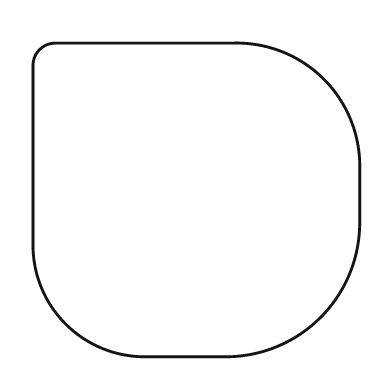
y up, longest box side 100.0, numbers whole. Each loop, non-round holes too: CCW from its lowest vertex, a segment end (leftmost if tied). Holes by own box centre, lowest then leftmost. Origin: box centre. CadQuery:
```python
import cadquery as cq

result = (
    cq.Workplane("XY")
    .moveTo(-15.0, -48.0)
    .lineTo(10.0, -48.0)
    .threePointArc((38.0, -36.0), (50.0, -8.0))
    .lineTo(50.0, 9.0)
    .threePointArc((39.0, 37.0), (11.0, 48.0))
    .lineTo(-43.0, 48.0)
    .threePointArc((-48.0, 46.0), (-50.0, 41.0))
    .lineTo(-50.0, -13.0)
    .threePointArc((-40.0, -38.0), (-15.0, -48.0))
    .close()
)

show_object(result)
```